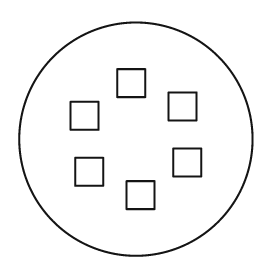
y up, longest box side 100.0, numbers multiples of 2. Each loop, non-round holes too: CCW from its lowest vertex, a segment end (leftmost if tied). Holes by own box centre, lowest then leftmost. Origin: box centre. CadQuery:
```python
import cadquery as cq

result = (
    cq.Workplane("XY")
    .moveTo(0.0, 0.0)
    .circle(50.0)
    .moveTo(-4.0, -30.0)
    .lineTo(8.0, -30.0)
    .lineTo(8.0, -18.0)
    .lineTo(-4.0, -18.0)
    .close()
    .moveTo(-26.0, -20.0)
    .lineTo(-14.0, -20.0)
    .lineTo(-14.0, -8.0)
    .lineTo(-26.0, -8.0)
    .close()
    .moveTo(16.0, -16.0)
    .lineTo(28.0, -16.0)
    .lineTo(28.0, -4.0)
    .lineTo(16.0, -4.0)
    .close()
    .moveTo(-28.0, 4.0)
    .lineTo(-16.0, 4.0)
    .lineTo(-16.0, 16.0)
    .lineTo(-28.0, 16.0)
    .close()
    .moveTo(14.0, 8.0)
    .lineTo(26.0, 8.0)
    .lineTo(26.0, 20.0)
    .lineTo(14.0, 20.0)
    .close()
    .moveTo(-8.0, 18.0)
    .lineTo(4.0, 18.0)
    .lineTo(4.0, 30.0)
    .lineTo(-8.0, 30.0)
    .close()
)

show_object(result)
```